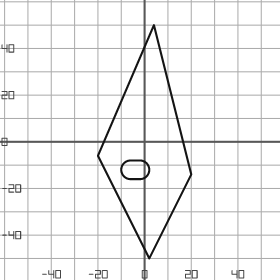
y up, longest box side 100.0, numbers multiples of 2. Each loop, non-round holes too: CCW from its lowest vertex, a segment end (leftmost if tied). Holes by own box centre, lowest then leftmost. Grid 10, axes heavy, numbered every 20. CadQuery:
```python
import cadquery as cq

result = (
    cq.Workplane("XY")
    .moveTo(2.0, -50.0)
    .lineTo(20.0, -14.0)
    .lineTo(4.0, 50.0)
    .lineTo(-20.0, -6.0)
    .close()
    .moveTo(-6.0, -16.0)
    .lineTo(-2.0, -16.0)
    .threePointArc((2.0, -12.0), (-2.0, -8.0))
    .lineTo(-6.0, -8.0)
    .threePointArc((-10.0, -12.0), (-6.0, -16.0))
    .close()
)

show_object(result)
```